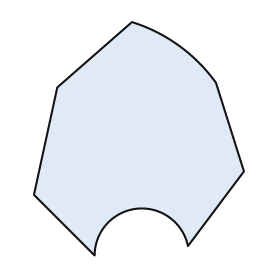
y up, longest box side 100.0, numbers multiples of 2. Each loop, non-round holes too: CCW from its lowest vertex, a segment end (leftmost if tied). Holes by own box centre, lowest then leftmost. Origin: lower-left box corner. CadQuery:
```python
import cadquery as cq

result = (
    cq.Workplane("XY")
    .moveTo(26.0, 0.0)
    .threePointArc((44.0, 20.0), (66.0, 4.0))
    .lineTo(90.0, 36.0)
    .lineTo(78.0, 74.0)
    .threePointArc((62.0, 90.0), (42.0, 100.0))
    .lineTo(10.0, 72.0)
    .lineTo(0.0, 26.0)
    .close()
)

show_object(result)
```